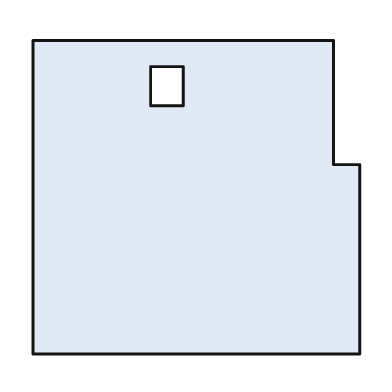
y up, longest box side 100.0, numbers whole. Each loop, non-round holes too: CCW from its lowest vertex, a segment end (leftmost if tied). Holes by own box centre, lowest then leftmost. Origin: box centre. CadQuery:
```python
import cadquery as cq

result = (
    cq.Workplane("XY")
    .moveTo(-50.0, -48.0)
    .lineTo(50.0, -48.0)
    .lineTo(50.0, 10.0)
    .lineTo(42.0, 10.0)
    .lineTo(42.0, 48.0)
    .lineTo(-50.0, 48.0)
    .close()
    .moveTo(-14.0, 28.0)
    .lineTo(-4.0, 28.0)
    .lineTo(-4.0, 40.0)
    .lineTo(-14.0, 40.0)
    .close()
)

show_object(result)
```